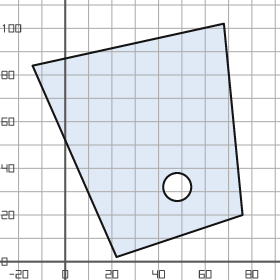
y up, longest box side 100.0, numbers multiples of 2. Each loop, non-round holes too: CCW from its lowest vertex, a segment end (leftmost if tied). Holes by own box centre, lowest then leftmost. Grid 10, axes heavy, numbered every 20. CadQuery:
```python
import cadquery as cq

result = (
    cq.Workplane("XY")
    .moveTo(22.0, 2.0)
    .lineTo(76.0, 20.0)
    .lineTo(68.0, 102.0)
    .lineTo(-14.0, 84.0)
    .close()
    .moveTo(48.0, 32.0)
    .circle(6.0)
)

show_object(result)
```